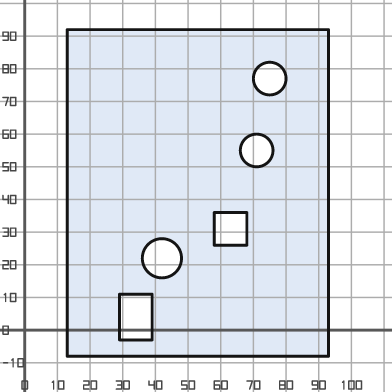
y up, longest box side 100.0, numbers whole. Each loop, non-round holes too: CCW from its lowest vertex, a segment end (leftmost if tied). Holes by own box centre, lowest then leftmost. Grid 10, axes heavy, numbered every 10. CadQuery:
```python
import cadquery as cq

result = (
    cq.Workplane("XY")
    .moveTo(13.0, -8.0)
    .lineTo(93.0, -8.0)
    .lineTo(93.0, 92.0)
    .lineTo(13.0, 92.0)
    .close()
    .moveTo(29.0, -3.0)
    .lineTo(39.0, -3.0)
    .lineTo(39.0, 11.0)
    .lineTo(29.0, 11.0)
    .close()
    .moveTo(42.0, 22.0)
    .circle(6.0)
    .moveTo(58.0, 26.0)
    .lineTo(68.0, 26.0)
    .lineTo(68.0, 36.0)
    .lineTo(58.0, 36.0)
    .close()
    .moveTo(71.0, 55.0)
    .circle(5.0)
    .moveTo(75.0, 77.0)
    .circle(5.0)
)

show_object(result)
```